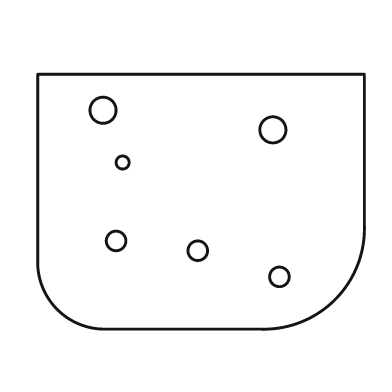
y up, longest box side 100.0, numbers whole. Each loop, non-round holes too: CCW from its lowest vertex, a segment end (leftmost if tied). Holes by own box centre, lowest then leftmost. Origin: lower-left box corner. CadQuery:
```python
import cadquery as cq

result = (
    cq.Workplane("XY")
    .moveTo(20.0, 0.0)
    .lineTo(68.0, 0.0)
    .threePointArc((91.0, 9.0), (100.0, 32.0))
    .lineTo(100.0, 78.0)
    .lineTo(0.0, 78.0)
    .lineTo(0.0, 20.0)
    .threePointArc((6.0, 6.0), (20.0, 0.0))
    .close()
    .moveTo(74.0, 16.0)
    .circle(3.0)
    .moveTo(49.0, 24.0)
    .circle(3.0)
    .moveTo(24.0, 27.0)
    .circle(3.0)
    .moveTo(26.0, 51.0)
    .circle(2.0)
    .moveTo(72.0, 61.0)
    .circle(4.0)
    .moveTo(20.0, 67.0)
    .circle(4.0)
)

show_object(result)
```